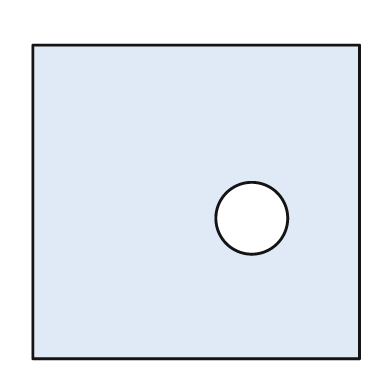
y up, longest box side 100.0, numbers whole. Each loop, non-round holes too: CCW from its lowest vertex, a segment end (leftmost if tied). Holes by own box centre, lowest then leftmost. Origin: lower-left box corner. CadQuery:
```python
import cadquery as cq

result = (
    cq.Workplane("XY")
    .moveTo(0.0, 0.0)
    .lineTo(100.0, 0.0)
    .lineTo(100.0, 96.0)
    .lineTo(0.0, 96.0)
    .close()
    .moveTo(67.0, 43.0)
    .circle(11.0)
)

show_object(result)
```